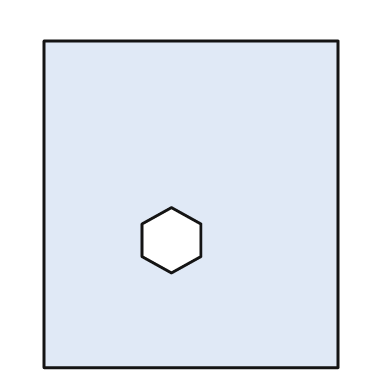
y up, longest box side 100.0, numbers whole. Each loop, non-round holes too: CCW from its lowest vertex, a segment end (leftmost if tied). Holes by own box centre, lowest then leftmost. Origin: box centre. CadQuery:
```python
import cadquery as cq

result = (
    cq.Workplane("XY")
    .moveTo(-45.0, -50.0)
    .lineTo(45.0, -50.0)
    .lineTo(45.0, 50.0)
    .lineTo(-45.0, 50.0)
    .close()
    .moveTo(-6.0, -21.0)
    .lineTo(3.0, -16.0)
    .lineTo(3.0, -6.0)
    .lineTo(-6.0, -1.0)
    .lineTo(-15.0, -6.0)
    .lineTo(-15.0, -16.0)
    .close()
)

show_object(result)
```